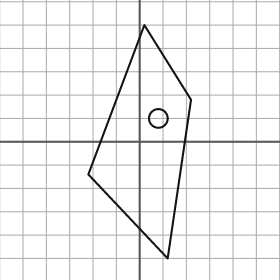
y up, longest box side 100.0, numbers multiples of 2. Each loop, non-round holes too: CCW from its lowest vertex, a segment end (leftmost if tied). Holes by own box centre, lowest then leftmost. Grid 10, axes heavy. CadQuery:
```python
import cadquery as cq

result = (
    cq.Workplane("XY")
    .moveTo(12.0, -50.0)
    .lineTo(22.0, 18.0)
    .lineTo(2.0, 50.0)
    .lineTo(-22.0, -14.0)
    .close()
    .moveTo(8.0, 10.0)
    .circle(4.0)
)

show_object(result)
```